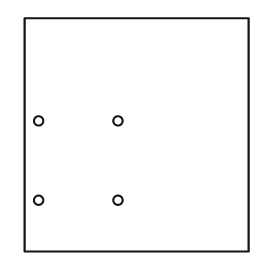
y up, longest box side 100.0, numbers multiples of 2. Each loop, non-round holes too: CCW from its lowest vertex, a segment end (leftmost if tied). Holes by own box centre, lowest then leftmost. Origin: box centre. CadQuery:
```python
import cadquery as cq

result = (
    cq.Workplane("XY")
    .moveTo(-48.0, -50.0)
    .lineTo(48.0, -50.0)
    .lineTo(48.0, 50.0)
    .lineTo(-48.0, 50.0)
    .close()
    .moveTo(-42.0, -28.0)
    .circle(2.0)
    .moveTo(-8.0, -28.0)
    .circle(2.0)
    .moveTo(-42.0, 6.0)
    .circle(2.0)
    .moveTo(-8.0, 6.0)
    .circle(2.0)
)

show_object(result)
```